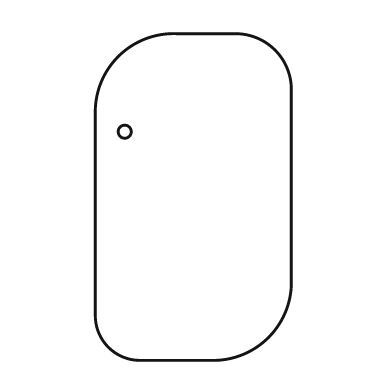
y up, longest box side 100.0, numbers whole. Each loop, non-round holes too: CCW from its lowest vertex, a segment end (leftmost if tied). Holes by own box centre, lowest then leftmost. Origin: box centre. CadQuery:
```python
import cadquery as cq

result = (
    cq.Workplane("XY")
    .moveTo(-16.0, -50.0)
    .lineTo(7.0, -50.0)
    .threePointArc((23.0, -43.0), (30.0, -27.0))
    .lineTo(30.0, 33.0)
    .threePointArc((25.0, 45.0), (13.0, 50.0))
    .lineTo(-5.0, 50.0)
    .threePointArc((-23.0, 43.0), (-30.0, 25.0))
    .lineTo(-30.0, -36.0)
    .threePointArc((-26.0, -46.0), (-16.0, -50.0))
    .close()
    .moveTo(-21.0, 20.0)
    .circle(2.0)
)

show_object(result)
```